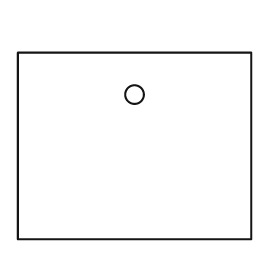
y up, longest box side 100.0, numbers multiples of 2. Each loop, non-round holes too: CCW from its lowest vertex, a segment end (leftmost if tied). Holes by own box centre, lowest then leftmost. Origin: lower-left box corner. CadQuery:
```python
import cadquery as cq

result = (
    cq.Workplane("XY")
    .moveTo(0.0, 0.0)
    .lineTo(100.0, 0.0)
    .lineTo(100.0, 80.0)
    .lineTo(0.0, 80.0)
    .close()
    .moveTo(50.0, 62.0)
    .circle(4.0)
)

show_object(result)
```